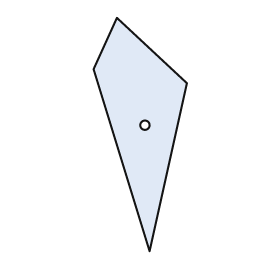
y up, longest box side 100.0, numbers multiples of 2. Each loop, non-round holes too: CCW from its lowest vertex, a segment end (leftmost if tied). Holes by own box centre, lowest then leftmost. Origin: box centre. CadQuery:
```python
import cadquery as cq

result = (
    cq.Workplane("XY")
    .moveTo(4.0, -50.0)
    .lineTo(20.0, 22.0)
    .lineTo(-10.0, 50.0)
    .lineTo(-20.0, 28.0)
    .close()
    .moveTo(2.0, 4.0)
    .circle(2.0)
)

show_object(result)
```